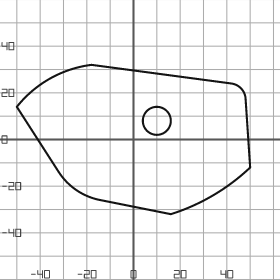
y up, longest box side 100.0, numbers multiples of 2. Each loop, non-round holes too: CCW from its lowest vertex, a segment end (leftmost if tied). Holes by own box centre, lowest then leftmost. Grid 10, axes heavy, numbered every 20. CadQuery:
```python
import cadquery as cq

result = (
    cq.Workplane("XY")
    .moveTo(16.0, -32.0)
    .threePointArc((34.0, -24.0), (50.0, -12.0))
    .lineTo(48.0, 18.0)
    .threePointArc((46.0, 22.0), (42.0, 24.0))
    .lineTo(-18.0, 32.0)
    .threePointArc((-36.0, 26.0), (-50.0, 14.0))
    .lineTo(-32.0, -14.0)
    .threePointArc((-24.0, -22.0), (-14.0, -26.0))
    .close()
    .moveTo(10.0, 8.0)
    .circle(6.0)
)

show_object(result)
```